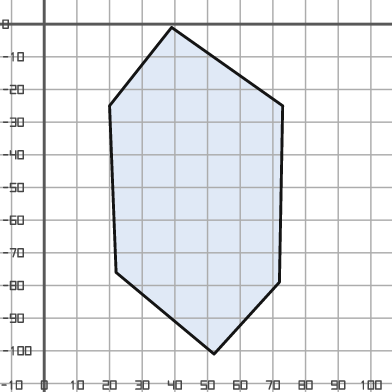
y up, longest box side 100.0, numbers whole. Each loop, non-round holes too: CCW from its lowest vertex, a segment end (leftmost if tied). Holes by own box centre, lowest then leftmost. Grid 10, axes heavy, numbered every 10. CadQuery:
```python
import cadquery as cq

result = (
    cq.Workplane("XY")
    .moveTo(52.0, -101.0)
    .lineTo(72.0, -79.0)
    .lineTo(73.0, -25.0)
    .lineTo(39.0, -1.0)
    .lineTo(20.0, -25.0)
    .lineTo(22.0, -76.0)
    .close()
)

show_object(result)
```